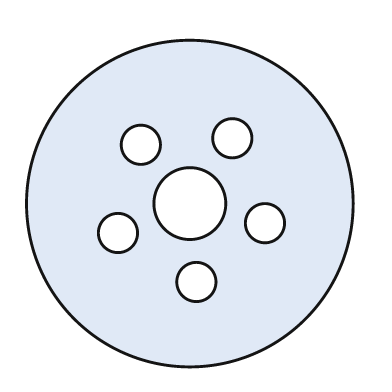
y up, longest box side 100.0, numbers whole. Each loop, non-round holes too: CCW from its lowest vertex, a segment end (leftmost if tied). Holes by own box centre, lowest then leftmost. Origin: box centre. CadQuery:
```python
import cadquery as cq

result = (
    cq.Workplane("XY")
    .moveTo(0.0, 0.0)
    .circle(50.0)
    .moveTo(2.0, -24.0)
    .circle(6.0)
    .moveTo(-22.0, -9.0)
    .circle(6.0)
    .moveTo(23.0, -6.0)
    .circle(6.0)
    .moveTo(0.0, 0.0)
    .circle(11.0)
    .moveTo(-15.0, 18.0)
    .circle(6.0)
    .moveTo(13.0, 20.0)
    .circle(6.0)
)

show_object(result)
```